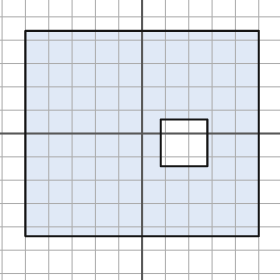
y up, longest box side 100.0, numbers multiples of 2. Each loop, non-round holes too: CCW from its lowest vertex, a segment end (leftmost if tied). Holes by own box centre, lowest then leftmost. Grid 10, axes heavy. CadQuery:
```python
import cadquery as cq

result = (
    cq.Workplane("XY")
    .moveTo(-50.0, -44.0)
    .lineTo(50.0, -44.0)
    .lineTo(50.0, 44.0)
    .lineTo(-50.0, 44.0)
    .close()
    .moveTo(8.0, -14.0)
    .lineTo(28.0, -14.0)
    .lineTo(28.0, 6.0)
    .lineTo(8.0, 6.0)
    .close()
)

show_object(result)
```